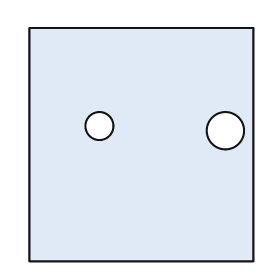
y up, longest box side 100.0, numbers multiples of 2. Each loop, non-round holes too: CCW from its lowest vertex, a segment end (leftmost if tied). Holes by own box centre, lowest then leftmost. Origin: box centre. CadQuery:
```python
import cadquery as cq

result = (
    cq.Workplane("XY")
    .moveTo(-48.0, -50.0)
    .lineTo(48.0, -50.0)
    .lineTo(48.0, 50.0)
    .lineTo(-48.0, 50.0)
    .close()
    .moveTo(36.0, 6.0)
    .circle(8.0)
    .moveTo(-18.0, 8.0)
    .circle(6.0)
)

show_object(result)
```